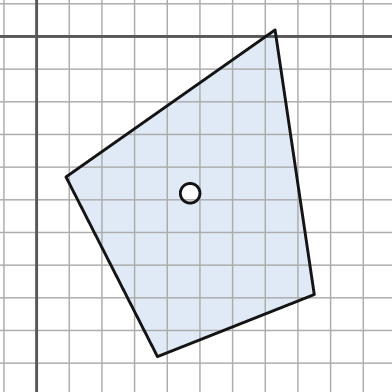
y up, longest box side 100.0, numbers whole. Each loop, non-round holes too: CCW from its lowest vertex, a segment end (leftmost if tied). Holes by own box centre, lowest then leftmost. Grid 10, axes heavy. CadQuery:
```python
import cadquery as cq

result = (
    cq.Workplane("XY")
    .moveTo(37.0, -98.0)
    .lineTo(85.0, -79.0)
    .lineTo(73.0, 2.0)
    .lineTo(9.0, -43.0)
    .close()
    .moveTo(47.0, -48.0)
    .circle(3.0)
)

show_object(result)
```